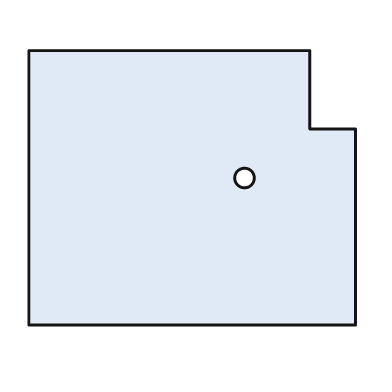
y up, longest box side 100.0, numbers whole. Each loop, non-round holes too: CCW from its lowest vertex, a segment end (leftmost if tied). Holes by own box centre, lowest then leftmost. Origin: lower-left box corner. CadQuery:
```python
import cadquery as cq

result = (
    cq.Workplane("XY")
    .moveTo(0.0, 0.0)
    .lineTo(100.0, 0.0)
    .lineTo(100.0, 60.0)
    .lineTo(86.0, 60.0)
    .lineTo(86.0, 84.0)
    .lineTo(0.0, 84.0)
    .close()
    .moveTo(66.0, 45.0)
    .circle(3.0)
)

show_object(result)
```